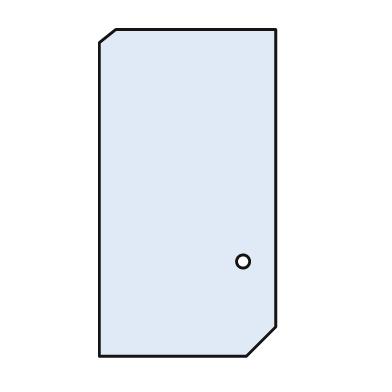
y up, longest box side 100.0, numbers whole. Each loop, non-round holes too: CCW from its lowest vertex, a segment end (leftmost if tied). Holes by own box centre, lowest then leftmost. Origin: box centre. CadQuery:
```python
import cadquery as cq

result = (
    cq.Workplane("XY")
    .moveTo(-27.0, -50.0)
    .lineTo(18.0, -50.0)
    .lineTo(27.0, -41.0)
    .lineTo(27.0, 50.0)
    .lineTo(-22.0, 50.0)
    .lineTo(-27.0, 46.0)
    .close()
    .moveTo(17.0, -21.0)
    .circle(2.0)
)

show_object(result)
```